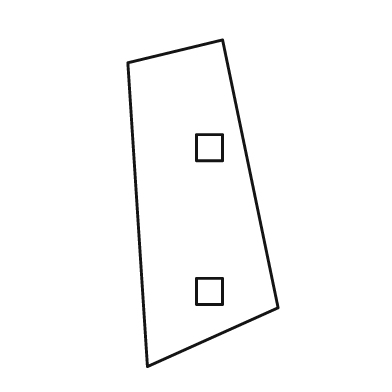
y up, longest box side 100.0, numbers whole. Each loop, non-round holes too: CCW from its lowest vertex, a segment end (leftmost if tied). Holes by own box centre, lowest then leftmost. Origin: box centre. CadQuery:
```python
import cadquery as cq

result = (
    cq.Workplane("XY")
    .moveTo(-17.0, -50.0)
    .lineTo(23.0, -32.0)
    .lineTo(6.0, 50.0)
    .lineTo(-23.0, 43.0)
    .close()
    .moveTo(-2.0, -31.0)
    .lineTo(6.0, -31.0)
    .lineTo(6.0, -23.0)
    .lineTo(-2.0, -23.0)
    .close()
    .moveTo(-2.0, 13.0)
    .lineTo(6.0, 13.0)
    .lineTo(6.0, 21.0)
    .lineTo(-2.0, 21.0)
    .close()
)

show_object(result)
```